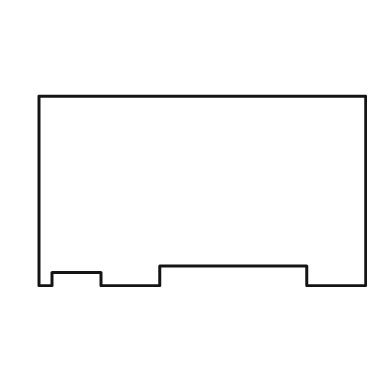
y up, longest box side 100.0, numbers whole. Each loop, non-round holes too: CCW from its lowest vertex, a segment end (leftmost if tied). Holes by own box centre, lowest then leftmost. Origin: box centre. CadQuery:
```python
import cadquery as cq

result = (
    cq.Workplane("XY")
    .moveTo(-50.0, -29.0)
    .lineTo(-46.0, -29.0)
    .lineTo(-46.0, -25.0)
    .lineTo(-31.0, -25.0)
    .lineTo(-31.0, -29.0)
    .lineTo(-13.0, -29.0)
    .lineTo(-13.0, -23.0)
    .lineTo(32.0, -23.0)
    .lineTo(32.0, -29.0)
    .lineTo(50.0, -29.0)
    .lineTo(50.0, 29.0)
    .lineTo(-50.0, 29.0)
    .close()
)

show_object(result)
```